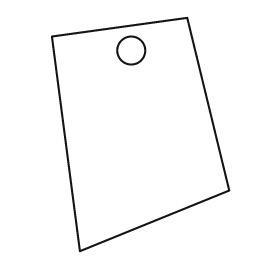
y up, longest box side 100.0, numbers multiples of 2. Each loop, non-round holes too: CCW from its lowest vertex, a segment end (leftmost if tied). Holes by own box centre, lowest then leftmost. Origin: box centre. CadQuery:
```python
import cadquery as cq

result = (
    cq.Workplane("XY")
    .moveTo(-26.0, -50.0)
    .lineTo(38.0, -24.0)
    .lineTo(20.0, 50.0)
    .lineTo(-38.0, 42.0)
    .close()
    .moveTo(-4.0, 36.0)
    .circle(6.0)
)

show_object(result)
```